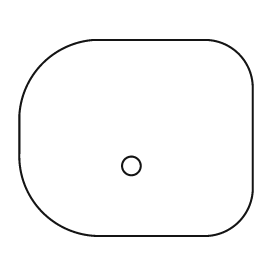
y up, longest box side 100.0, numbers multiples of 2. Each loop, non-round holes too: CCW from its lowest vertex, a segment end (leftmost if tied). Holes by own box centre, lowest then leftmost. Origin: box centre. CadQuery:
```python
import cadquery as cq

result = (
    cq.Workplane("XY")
    .moveTo(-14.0, -42.0)
    .lineTo(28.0, -42.0)
    .threePointArc((44.0, -36.0), (50.0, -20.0))
    .lineTo(50.0, 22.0)
    .threePointArc((44.0, 36.0), (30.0, 42.0))
    .lineTo(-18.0, 42.0)
    .threePointArc((-40.0, 32.0), (-50.0, 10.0))
    .lineTo(-50.0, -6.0)
    .threePointArc((-40.0, -32.0), (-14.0, -42.0))
    .close()
    .moveTo(-2.0, -12.0)
    .circle(4.0)
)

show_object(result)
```